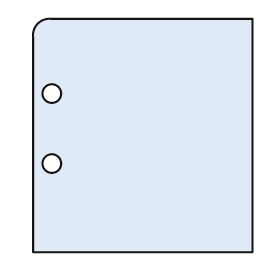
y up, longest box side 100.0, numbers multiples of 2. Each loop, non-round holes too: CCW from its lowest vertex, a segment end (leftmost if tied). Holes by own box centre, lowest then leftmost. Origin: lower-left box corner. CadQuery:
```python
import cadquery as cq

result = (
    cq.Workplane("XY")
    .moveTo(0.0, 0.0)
    .lineTo(94.0, 0.0)
    .lineTo(94.0, 100.0)
    .lineTo(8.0, 100.0)
    .threePointArc((2.0, 98.0), (0.0, 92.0))
    .close()
    .moveTo(8.0, 38.0)
    .circle(4.0)
    .moveTo(8.0, 68.0)
    .circle(4.0)
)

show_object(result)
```